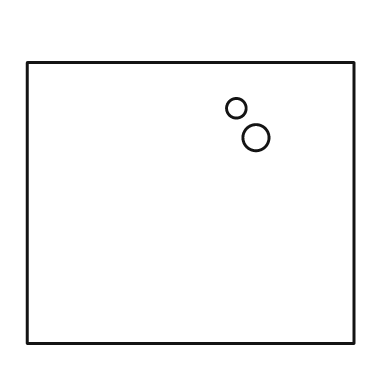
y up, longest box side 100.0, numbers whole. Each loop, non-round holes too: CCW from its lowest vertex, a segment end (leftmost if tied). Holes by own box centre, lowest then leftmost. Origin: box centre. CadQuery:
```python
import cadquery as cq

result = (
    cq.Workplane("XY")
    .moveTo(-50.0, -43.0)
    .lineTo(50.0, -43.0)
    .lineTo(50.0, 43.0)
    .lineTo(-50.0, 43.0)
    .close()
    .moveTo(20.0, 20.0)
    .circle(4.0)
    .moveTo(14.0, 29.0)
    .circle(3.0)
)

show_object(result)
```